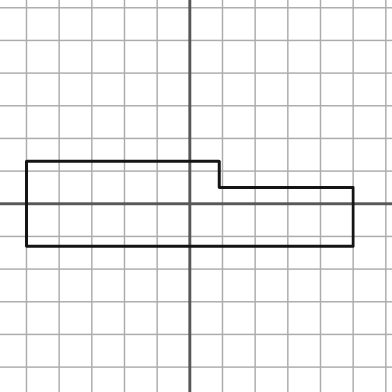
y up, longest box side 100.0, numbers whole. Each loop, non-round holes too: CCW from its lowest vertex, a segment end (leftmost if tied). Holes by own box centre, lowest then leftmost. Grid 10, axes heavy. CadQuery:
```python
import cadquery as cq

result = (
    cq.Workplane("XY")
    .moveTo(-50.0, -13.0)
    .lineTo(50.0, -13.0)
    .lineTo(50.0, 5.0)
    .lineTo(9.0, 5.0)
    .lineTo(9.0, 13.0)
    .lineTo(-50.0, 13.0)
    .close()
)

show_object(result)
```